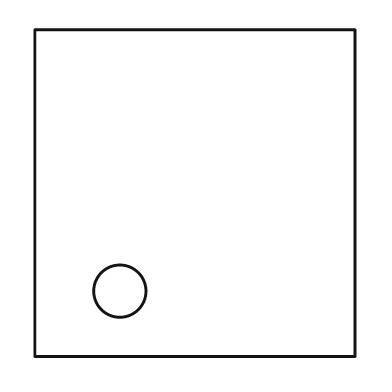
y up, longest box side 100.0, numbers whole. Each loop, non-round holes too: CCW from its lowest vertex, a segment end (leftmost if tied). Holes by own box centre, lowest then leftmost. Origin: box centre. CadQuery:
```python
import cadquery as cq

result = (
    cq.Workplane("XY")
    .moveTo(-49.0, -50.0)
    .lineTo(49.0, -50.0)
    .lineTo(49.0, 50.0)
    .lineTo(-49.0, 50.0)
    .close()
    .moveTo(-23.0, -30.0)
    .circle(8.0)
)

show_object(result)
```